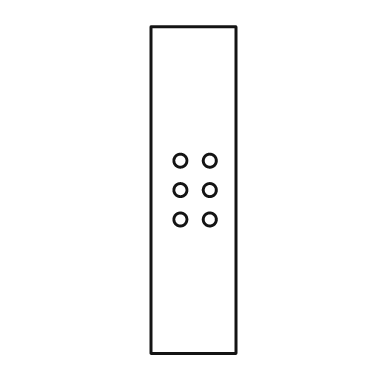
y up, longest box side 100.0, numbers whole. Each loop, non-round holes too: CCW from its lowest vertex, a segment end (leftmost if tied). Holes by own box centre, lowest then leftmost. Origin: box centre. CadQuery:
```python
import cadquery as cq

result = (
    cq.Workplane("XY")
    .moveTo(-13.0, -50.0)
    .lineTo(13.0, -50.0)
    .lineTo(13.0, 50.0)
    .lineTo(-13.0, 50.0)
    .close()
    .moveTo(-4.0, -9.0)
    .circle(2.0)
    .moveTo(5.0, -9.0)
    .circle(2.0)
    .moveTo(-4.0, 0.0)
    .circle(2.0)
    .moveTo(5.0, 0.0)
    .circle(2.0)
    .moveTo(-4.0, 9.0)
    .circle(2.0)
    .moveTo(5.0, 9.0)
    .circle(2.0)
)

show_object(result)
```